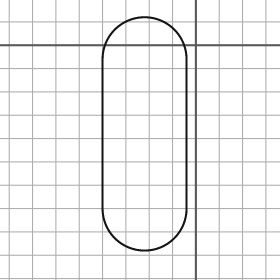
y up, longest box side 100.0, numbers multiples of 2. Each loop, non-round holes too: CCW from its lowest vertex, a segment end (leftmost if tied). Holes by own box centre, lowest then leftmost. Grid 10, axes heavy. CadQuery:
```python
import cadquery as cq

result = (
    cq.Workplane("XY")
    .moveTo(-40.0, -70.0)
    .threePointArc((-22.0, -88.0), (-4.0, -70.0))
    .lineTo(-4.0, -6.0)
    .threePointArc((-22.0, 12.0), (-40.0, -6.0))
    .close()
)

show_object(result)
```